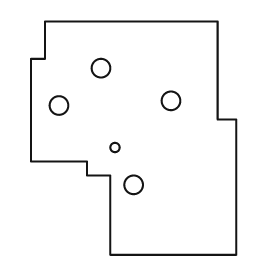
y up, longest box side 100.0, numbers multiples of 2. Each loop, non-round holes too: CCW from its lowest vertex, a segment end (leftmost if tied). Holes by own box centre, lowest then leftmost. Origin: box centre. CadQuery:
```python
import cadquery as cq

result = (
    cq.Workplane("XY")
    .moveTo(-10.0, -50.0)
    .lineTo(44.0, -50.0)
    .lineTo(44.0, 8.0)
    .lineTo(36.0, 8.0)
    .lineTo(36.0, 50.0)
    .lineTo(-38.0, 50.0)
    .lineTo(-38.0, 34.0)
    .lineTo(-44.0, 34.0)
    .lineTo(-44.0, -10.0)
    .lineTo(-20.0, -10.0)
    .lineTo(-20.0, -16.0)
    .lineTo(-10.0, -16.0)
    .close()
    .moveTo(0.0, -20.0)
    .circle(4.0)
    .moveTo(-8.0, -4.0)
    .circle(2.0)
    .moveTo(-32.0, 14.0)
    .circle(4.0)
    .moveTo(16.0, 16.0)
    .circle(4.0)
    .moveTo(-14.0, 30.0)
    .circle(4.0)
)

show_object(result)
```